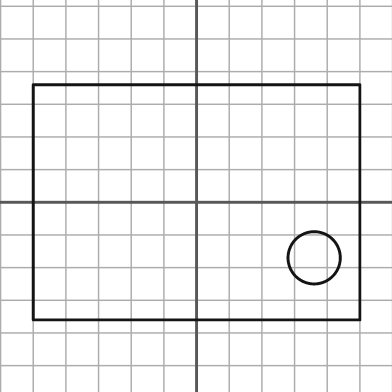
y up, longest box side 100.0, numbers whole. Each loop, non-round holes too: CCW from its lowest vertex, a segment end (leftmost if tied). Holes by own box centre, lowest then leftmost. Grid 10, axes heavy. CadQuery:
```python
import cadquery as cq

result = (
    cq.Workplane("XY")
    .moveTo(-50.0, -36.0)
    .lineTo(50.0, -36.0)
    .lineTo(50.0, 36.0)
    .lineTo(-50.0, 36.0)
    .close()
    .moveTo(36.0, -17.0)
    .circle(8.0)
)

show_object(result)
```